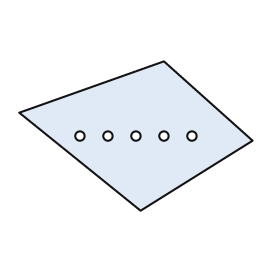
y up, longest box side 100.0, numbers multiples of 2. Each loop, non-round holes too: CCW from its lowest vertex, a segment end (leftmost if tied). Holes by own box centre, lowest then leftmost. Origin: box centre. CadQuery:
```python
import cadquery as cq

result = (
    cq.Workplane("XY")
    .moveTo(2.0, -32.0)
    .lineTo(50.0, -2.0)
    .lineTo(12.0, 32.0)
    .lineTo(-50.0, 10.0)
    .close()
    .moveTo(-24.0, 0.0)
    .circle(2.0)
    .moveTo(-12.0, 0.0)
    .circle(2.0)
    .moveTo(0.0, 0.0)
    .circle(2.0)
    .moveTo(12.0, 0.0)
    .circle(2.0)
    .moveTo(24.0, 0.0)
    .circle(2.0)
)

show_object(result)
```